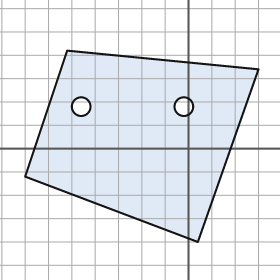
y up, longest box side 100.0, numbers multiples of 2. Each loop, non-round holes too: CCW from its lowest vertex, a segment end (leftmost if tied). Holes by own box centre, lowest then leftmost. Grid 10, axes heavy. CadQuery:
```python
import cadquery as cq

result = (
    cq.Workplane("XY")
    .moveTo(4.0, -40.0)
    .lineTo(30.0, 34.0)
    .lineTo(-52.0, 42.0)
    .lineTo(-70.0, -12.0)
    .close()
    .moveTo(-46.0, 18.0)
    .circle(4.0)
    .moveTo(-2.0, 18.0)
    .circle(4.0)
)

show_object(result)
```